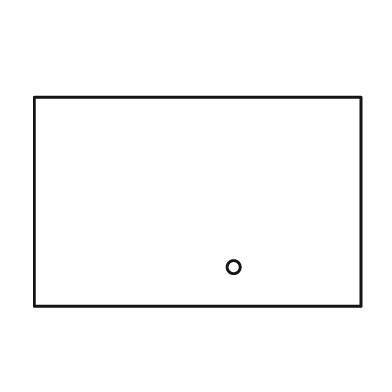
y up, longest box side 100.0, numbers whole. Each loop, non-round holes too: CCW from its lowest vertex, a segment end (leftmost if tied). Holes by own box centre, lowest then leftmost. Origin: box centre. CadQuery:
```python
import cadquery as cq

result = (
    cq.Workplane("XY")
    .moveTo(-50.0, -32.0)
    .lineTo(50.0, -32.0)
    .lineTo(50.0, 32.0)
    .lineTo(-50.0, 32.0)
    .close()
    .moveTo(11.0, -20.0)
    .circle(2.0)
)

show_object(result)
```